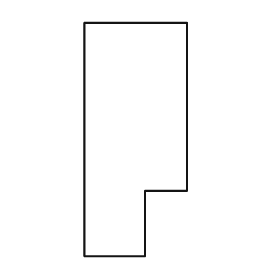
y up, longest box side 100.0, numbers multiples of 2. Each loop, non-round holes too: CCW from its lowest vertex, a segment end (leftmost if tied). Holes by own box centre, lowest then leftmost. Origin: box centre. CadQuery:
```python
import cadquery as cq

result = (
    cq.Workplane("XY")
    .moveTo(-22.0, -50.0)
    .lineTo(4.0, -50.0)
    .lineTo(4.0, -22.0)
    .lineTo(22.0, -22.0)
    .lineTo(22.0, 50.0)
    .lineTo(-22.0, 50.0)
    .close()
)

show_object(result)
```